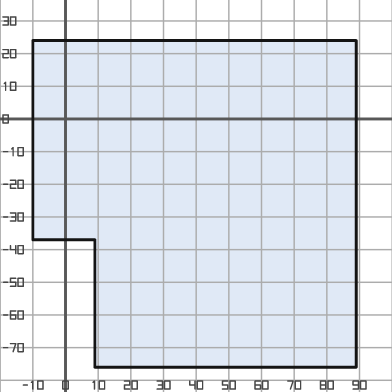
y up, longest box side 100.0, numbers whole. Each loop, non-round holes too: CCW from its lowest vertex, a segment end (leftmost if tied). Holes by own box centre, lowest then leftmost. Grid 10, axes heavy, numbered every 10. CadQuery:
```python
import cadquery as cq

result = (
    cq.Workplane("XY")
    .moveTo(9.0, -76.0)
    .lineTo(89.0, -76.0)
    .lineTo(89.0, 24.0)
    .lineTo(-10.0, 24.0)
    .lineTo(-10.0, -37.0)
    .lineTo(9.0, -37.0)
    .close()
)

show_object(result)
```